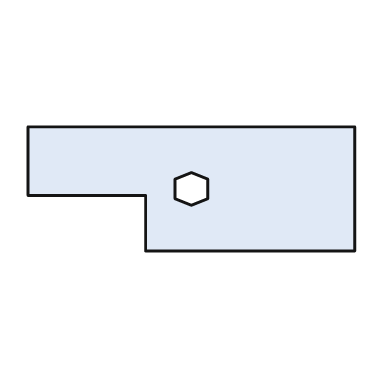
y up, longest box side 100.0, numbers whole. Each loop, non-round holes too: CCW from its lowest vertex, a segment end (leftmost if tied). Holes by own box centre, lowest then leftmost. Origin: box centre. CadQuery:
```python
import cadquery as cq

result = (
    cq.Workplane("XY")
    .moveTo(-14.0, -19.0)
    .lineTo(50.0, -19.0)
    .lineTo(50.0, 19.0)
    .lineTo(-50.0, 19.0)
    .lineTo(-50.0, -2.0)
    .lineTo(-14.0, -2.0)
    .close()
    .moveTo(0.0, -5.0)
    .lineTo(5.0, -3.0)
    .lineTo(5.0, 3.0)
    .lineTo(0.0, 5.0)
    .lineTo(-5.0, 3.0)
    .lineTo(-5.0, -3.0)
    .close()
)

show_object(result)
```